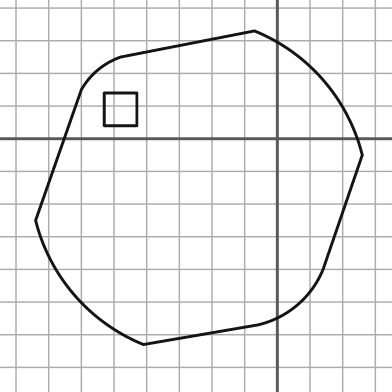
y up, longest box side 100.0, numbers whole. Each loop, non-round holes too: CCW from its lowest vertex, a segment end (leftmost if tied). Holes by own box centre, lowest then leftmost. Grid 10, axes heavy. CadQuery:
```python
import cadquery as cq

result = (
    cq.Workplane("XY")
    .moveTo(-41.0, -63.0)
    .lineTo(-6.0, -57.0)
    .threePointArc((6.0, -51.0), (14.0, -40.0))
    .lineTo(26.0, -5.0)
    .threePointArc((14.0, 18.0), (-7.0, 33.0))
    .lineTo(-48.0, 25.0)
    .threePointArc((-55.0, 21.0), (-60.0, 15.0))
    .lineTo(-74.0, -25.0)
    .threePointArc((-62.0, -48.0), (-41.0, -63.0))
    .close()
    .moveTo(-53.0, 4.0)
    .lineTo(-43.0, 4.0)
    .lineTo(-43.0, 14.0)
    .lineTo(-53.0, 14.0)
    .close()
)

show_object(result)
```